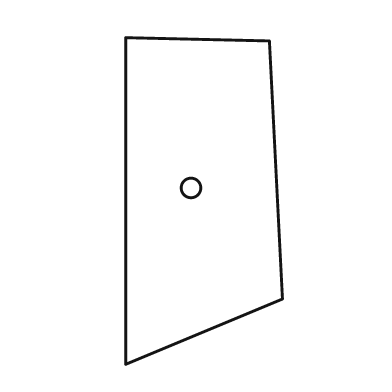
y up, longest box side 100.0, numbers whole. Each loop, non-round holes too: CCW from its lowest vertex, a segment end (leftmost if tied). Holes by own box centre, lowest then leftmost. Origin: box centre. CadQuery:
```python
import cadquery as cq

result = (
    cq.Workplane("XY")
    .moveTo(-24.0, -50.0)
    .lineTo(24.0, -30.0)
    .lineTo(20.0, 49.0)
    .lineTo(-24.0, 50.0)
    .close()
    .moveTo(-4.0, 4.0)
    .circle(3.0)
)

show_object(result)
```